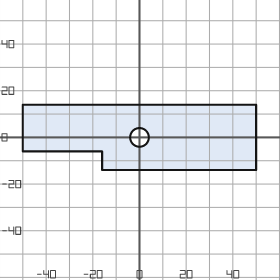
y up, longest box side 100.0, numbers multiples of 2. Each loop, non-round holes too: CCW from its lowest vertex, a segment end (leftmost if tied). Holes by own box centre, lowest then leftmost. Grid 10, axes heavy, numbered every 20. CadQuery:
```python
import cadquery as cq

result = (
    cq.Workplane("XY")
    .moveTo(-16.0, -14.0)
    .lineTo(50.0, -14.0)
    .lineTo(50.0, 14.0)
    .lineTo(-50.0, 14.0)
    .lineTo(-50.0, -6.0)
    .lineTo(-16.0, -6.0)
    .close()
    .moveTo(0.0, 0.0)
    .circle(4.0)
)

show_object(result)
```